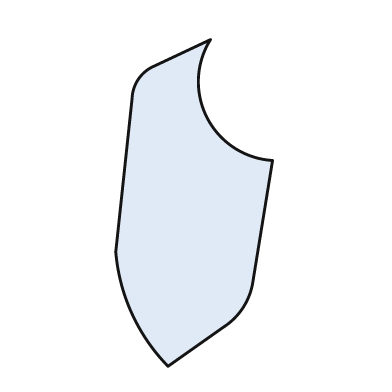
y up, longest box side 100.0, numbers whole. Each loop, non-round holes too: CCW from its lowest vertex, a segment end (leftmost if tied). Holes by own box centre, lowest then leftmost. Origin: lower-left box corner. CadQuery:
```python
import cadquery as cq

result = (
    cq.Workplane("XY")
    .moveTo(16.0, 0.0)
    .lineTo(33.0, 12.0)
    .threePointArc((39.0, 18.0), (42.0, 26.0))
    .lineTo(48.0, 63.0)
    .threePointArc((28.0, 76.0), (29.0, 100.0))
    .lineTo(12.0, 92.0)
    .threePointArc((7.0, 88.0), (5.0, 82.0))
    .lineTo(0.0, 35.0)
    .threePointArc((5.0, 16.0), (16.0, 0.0))
    .close()
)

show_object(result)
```